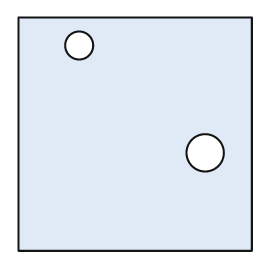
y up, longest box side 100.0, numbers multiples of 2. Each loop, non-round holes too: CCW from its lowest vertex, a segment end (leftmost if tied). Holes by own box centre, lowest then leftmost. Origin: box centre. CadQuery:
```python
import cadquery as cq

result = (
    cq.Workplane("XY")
    .moveTo(-50.0, -50.0)
    .lineTo(50.0, -50.0)
    .lineTo(50.0, 50.0)
    .lineTo(-50.0, 50.0)
    .close()
    .moveTo(30.0, -8.0)
    .circle(8.0)
    .moveTo(-24.0, 38.0)
    .circle(6.0)
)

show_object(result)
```